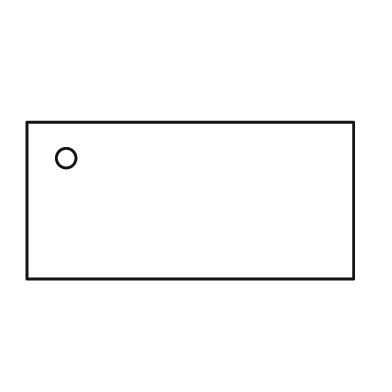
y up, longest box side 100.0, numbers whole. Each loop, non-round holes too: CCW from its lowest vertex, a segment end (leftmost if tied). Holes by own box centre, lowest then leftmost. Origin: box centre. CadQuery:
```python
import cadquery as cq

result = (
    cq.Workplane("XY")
    .moveTo(-50.0, -24.0)
    .lineTo(50.0, -24.0)
    .lineTo(50.0, 24.0)
    .lineTo(-50.0, 24.0)
    .close()
    .moveTo(-38.0, 13.0)
    .circle(3.0)
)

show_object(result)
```